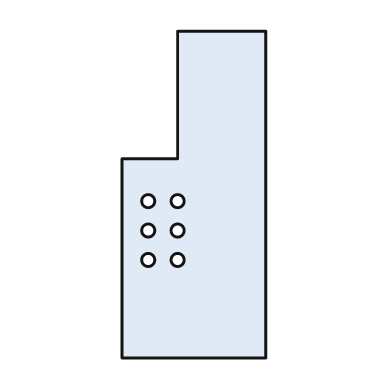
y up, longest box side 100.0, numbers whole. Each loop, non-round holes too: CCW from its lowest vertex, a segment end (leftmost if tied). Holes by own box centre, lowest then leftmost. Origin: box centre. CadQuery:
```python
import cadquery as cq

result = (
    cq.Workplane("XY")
    .moveTo(-22.0, -50.0)
    .lineTo(22.0, -50.0)
    .lineTo(22.0, 50.0)
    .lineTo(-5.0, 50.0)
    .lineTo(-5.0, 11.0)
    .lineTo(-22.0, 11.0)
    .close()
    .moveTo(-14.0, -20.0)
    .circle(2.0)
    .moveTo(-5.0, -20.0)
    .circle(2.0)
    .moveTo(-14.0, -11.0)
    .circle(2.0)
    .moveTo(-5.0, -11.0)
    .circle(2.0)
    .moveTo(-14.0, -2.0)
    .circle(2.0)
    .moveTo(-5.0, -2.0)
    .circle(2.0)
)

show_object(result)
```